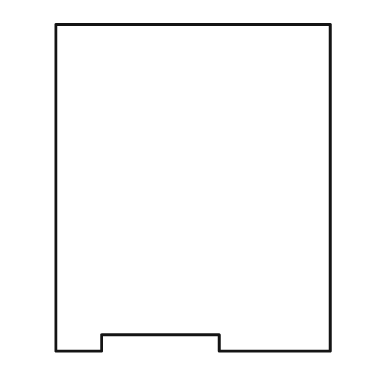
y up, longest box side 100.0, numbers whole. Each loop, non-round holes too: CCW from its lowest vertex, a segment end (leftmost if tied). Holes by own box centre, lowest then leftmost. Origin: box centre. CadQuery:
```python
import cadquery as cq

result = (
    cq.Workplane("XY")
    .moveTo(-42.0, -50.0)
    .lineTo(-28.0, -50.0)
    .lineTo(-28.0, -45.0)
    .lineTo(8.0, -45.0)
    .lineTo(8.0, -50.0)
    .lineTo(42.0, -50.0)
    .lineTo(42.0, 50.0)
    .lineTo(-42.0, 50.0)
    .close()
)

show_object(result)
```